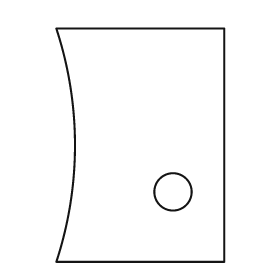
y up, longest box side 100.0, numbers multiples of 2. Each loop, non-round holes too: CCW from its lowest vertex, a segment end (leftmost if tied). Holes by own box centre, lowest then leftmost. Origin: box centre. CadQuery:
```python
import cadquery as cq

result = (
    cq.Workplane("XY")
    .moveTo(-36.0, -50.0)
    .lineTo(36.0, -50.0)
    .lineTo(36.0, 50.0)
    .lineTo(-36.0, 50.0)
    .threePointArc((-28.0, 0.0), (-36.0, -50.0))
    .close()
    .moveTo(14.0, -20.0)
    .circle(8.0)
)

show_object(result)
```